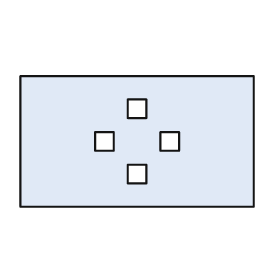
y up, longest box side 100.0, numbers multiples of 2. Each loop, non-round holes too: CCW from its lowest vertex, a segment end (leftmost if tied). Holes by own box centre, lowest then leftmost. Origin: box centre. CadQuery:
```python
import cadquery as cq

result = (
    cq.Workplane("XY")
    .moveTo(-50.0, -28.0)
    .lineTo(50.0, -28.0)
    .lineTo(50.0, 28.0)
    .lineTo(-50.0, 28.0)
    .close()
    .moveTo(-4.0, -18.0)
    .lineTo(4.0, -18.0)
    .lineTo(4.0, -10.0)
    .lineTo(-4.0, -10.0)
    .close()
    .moveTo(-18.0, -4.0)
    .lineTo(-10.0, -4.0)
    .lineTo(-10.0, 4.0)
    .lineTo(-18.0, 4.0)
    .close()
    .moveTo(10.0, -4.0)
    .lineTo(18.0, -4.0)
    .lineTo(18.0, 4.0)
    .lineTo(10.0, 4.0)
    .close()
    .moveTo(-4.0, 10.0)
    .lineTo(4.0, 10.0)
    .lineTo(4.0, 18.0)
    .lineTo(-4.0, 18.0)
    .close()
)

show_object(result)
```